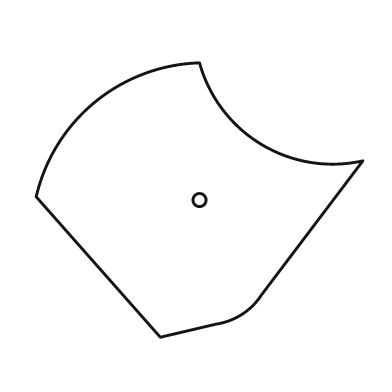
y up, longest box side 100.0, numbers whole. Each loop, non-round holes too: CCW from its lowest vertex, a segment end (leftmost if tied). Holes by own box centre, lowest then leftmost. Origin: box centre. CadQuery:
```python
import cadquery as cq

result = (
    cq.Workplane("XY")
    .moveTo(-12.0, -42.0)
    .lineTo(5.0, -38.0)
    .threePointArc((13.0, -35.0), (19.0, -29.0))
    .lineTo(50.0, 12.0)
    .threePointArc((19.0, 17.0), (0.0, 42.0))
    .threePointArc((-32.0, 30.0), (-50.0, 1.0))
    .close()
    .moveTo(0.0, 0.0)
    .circle(2.0)
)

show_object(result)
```